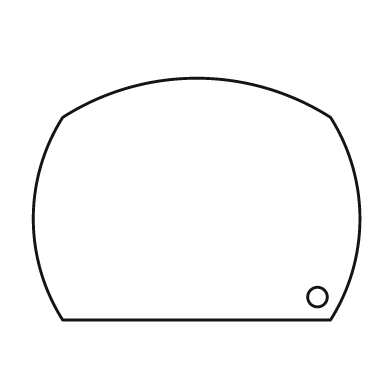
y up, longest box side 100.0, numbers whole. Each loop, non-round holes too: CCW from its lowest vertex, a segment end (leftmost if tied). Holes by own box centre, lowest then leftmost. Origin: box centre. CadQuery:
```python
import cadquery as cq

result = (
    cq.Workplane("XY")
    .moveTo(-41.0, -37.0)
    .lineTo(41.0, -37.0)
    .threePointArc((50.0, -6.0), (41.0, 25.0))
    .threePointArc((0.0, 37.0), (-41.0, 25.0))
    .threePointArc((-50.0, -6.0), (-41.0, -37.0))
    .close()
    .moveTo(37.0, -30.0)
    .circle(3.0)
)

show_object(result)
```